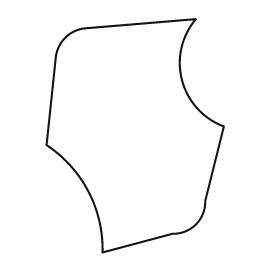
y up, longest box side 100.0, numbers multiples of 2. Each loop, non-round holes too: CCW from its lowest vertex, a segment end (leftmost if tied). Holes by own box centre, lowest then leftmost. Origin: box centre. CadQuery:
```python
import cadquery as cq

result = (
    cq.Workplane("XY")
    .moveTo(-14.0, -50.0)
    .lineTo(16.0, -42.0)
    .threePointArc((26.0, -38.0), (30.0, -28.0))
    .lineTo(38.0, 4.0)
    .threePointArc((20.0, 24.0), (26.0, 50.0))
    .lineTo(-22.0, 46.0)
    .threePointArc((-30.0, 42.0), (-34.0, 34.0))
    .lineTo(-38.0, -4.0)
    .threePointArc((-20.0, -24.0), (-14.0, -50.0))
    .close()
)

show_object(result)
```